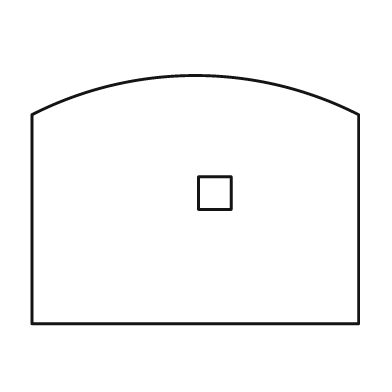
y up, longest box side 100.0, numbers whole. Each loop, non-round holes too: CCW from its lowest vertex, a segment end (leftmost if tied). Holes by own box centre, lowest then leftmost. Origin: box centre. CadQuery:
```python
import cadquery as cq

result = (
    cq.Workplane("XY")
    .moveTo(-50.0, -38.0)
    .lineTo(50.0, -38.0)
    .lineTo(50.0, 26.0)
    .threePointArc((0.0, 38.0), (-50.0, 26.0))
    .close()
    .moveTo(1.0, -3.0)
    .lineTo(11.0, -3.0)
    .lineTo(11.0, 7.0)
    .lineTo(1.0, 7.0)
    .close()
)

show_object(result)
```